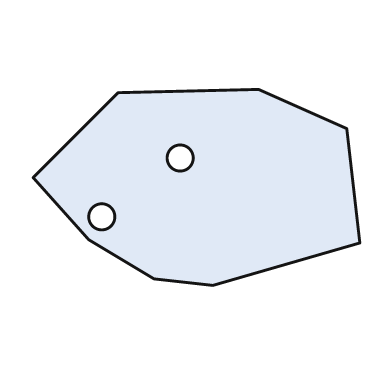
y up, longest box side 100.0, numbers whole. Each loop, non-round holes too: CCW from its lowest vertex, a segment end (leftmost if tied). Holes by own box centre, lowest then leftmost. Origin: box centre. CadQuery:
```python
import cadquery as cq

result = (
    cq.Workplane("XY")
    .moveTo(5.0, -30.0)
    .lineTo(50.0, -17.0)
    .lineTo(46.0, 18.0)
    .lineTo(19.0, 30.0)
    .lineTo(-24.0, 29.0)
    .lineTo(-50.0, 3.0)
    .lineTo(-33.0, -16.0)
    .lineTo(-13.0, -28.0)
    .close()
    .moveTo(-29.0, -9.0)
    .circle(4.0)
    .moveTo(-5.0, 9.0)
    .circle(4.0)
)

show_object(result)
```